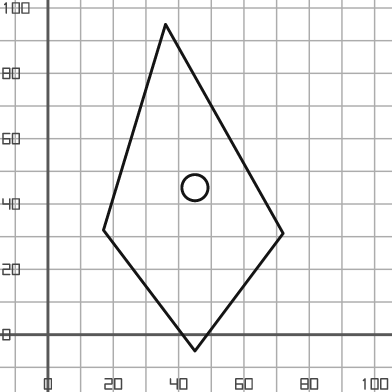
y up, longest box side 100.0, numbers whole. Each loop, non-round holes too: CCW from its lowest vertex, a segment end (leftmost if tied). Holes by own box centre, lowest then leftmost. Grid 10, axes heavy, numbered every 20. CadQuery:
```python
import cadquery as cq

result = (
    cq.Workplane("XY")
    .moveTo(45.0, -5.0)
    .lineTo(72.0, 31.0)
    .lineTo(36.0, 95.0)
    .lineTo(17.0, 32.0)
    .close()
    .moveTo(45.0, 45.0)
    .circle(4.0)
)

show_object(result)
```